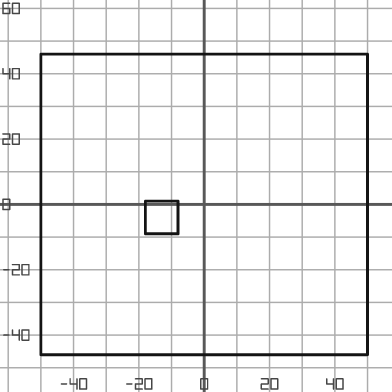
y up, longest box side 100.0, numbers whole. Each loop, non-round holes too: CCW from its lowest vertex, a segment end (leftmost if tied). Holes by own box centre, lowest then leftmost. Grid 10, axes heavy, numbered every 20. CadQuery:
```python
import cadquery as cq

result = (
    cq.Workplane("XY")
    .moveTo(-50.0, -46.0)
    .lineTo(50.0, -46.0)
    .lineTo(50.0, 46.0)
    .lineTo(-50.0, 46.0)
    .close()
    .moveTo(-18.0, -9.0)
    .lineTo(-8.0, -9.0)
    .lineTo(-8.0, 1.0)
    .lineTo(-18.0, 1.0)
    .close()
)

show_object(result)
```